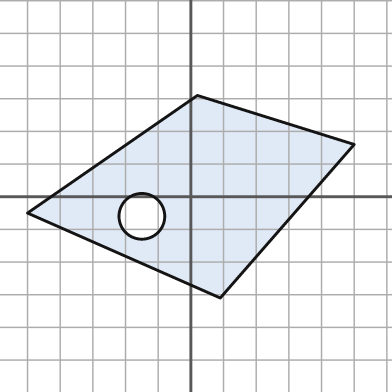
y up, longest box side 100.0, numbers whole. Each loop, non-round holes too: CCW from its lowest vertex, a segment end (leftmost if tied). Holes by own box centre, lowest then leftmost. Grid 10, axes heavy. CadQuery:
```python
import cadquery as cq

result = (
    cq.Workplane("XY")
    .moveTo(9.0, -31.0)
    .lineTo(50.0, 16.0)
    .lineTo(2.0, 31.0)
    .lineTo(-50.0, -5.0)
    .close()
    .moveTo(-15.0, -6.0)
    .circle(7.0)
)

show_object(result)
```